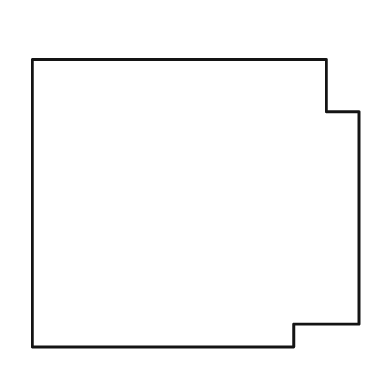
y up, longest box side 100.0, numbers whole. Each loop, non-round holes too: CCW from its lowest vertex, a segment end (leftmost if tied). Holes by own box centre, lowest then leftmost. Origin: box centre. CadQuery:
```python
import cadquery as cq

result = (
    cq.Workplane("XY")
    .moveTo(-50.0, -44.0)
    .lineTo(30.0, -44.0)
    .lineTo(30.0, -37.0)
    .lineTo(50.0, -37.0)
    .lineTo(50.0, 28.0)
    .lineTo(40.0, 28.0)
    .lineTo(40.0, 44.0)
    .lineTo(-50.0, 44.0)
    .close()
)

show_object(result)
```